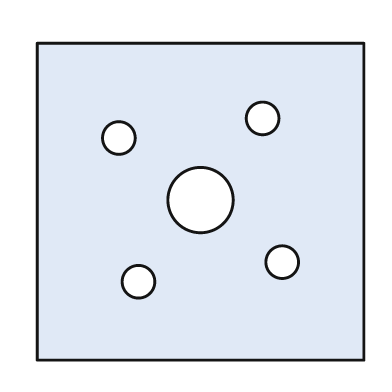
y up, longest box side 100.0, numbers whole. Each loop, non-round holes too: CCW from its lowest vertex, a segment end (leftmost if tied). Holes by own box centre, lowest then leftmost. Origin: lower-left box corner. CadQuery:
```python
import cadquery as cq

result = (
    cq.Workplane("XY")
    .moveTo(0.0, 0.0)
    .lineTo(100.0, 0.0)
    .lineTo(100.0, 97.0)
    .lineTo(0.0, 97.0)
    .close()
    .moveTo(31.0, 24.0)
    .circle(5.0)
    .moveTo(75.0, 30.0)
    .circle(5.0)
    .moveTo(50.0, 49.0)
    .circle(10.0)
    .moveTo(25.0, 68.0)
    .circle(5.0)
    .moveTo(69.0, 74.0)
    .circle(5.0)
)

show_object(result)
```